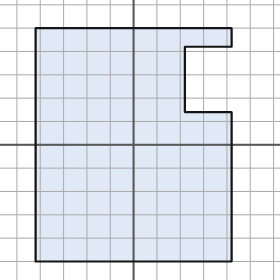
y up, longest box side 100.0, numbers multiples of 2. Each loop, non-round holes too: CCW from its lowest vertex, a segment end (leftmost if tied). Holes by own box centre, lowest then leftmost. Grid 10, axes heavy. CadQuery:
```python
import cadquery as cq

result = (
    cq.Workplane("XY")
    .moveTo(-42.0, -50.0)
    .lineTo(42.0, -50.0)
    .lineTo(42.0, 14.0)
    .lineTo(22.0, 14.0)
    .lineTo(22.0, 42.0)
    .lineTo(42.0, 42.0)
    .lineTo(42.0, 50.0)
    .lineTo(-42.0, 50.0)
    .close()
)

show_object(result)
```